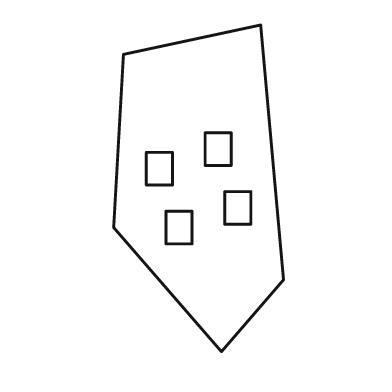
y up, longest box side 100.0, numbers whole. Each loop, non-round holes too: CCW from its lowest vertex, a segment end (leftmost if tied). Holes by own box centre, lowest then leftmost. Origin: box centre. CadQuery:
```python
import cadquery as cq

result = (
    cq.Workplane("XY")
    .moveTo(7.0, -50.0)
    .lineTo(26.0, -28.0)
    .lineTo(19.0, 50.0)
    .lineTo(-23.0, 41.0)
    .lineTo(-26.0, -12.0)
    .close()
    .moveTo(-10.0, -17.0)
    .lineTo(-2.0, -17.0)
    .lineTo(-2.0, -7.0)
    .lineTo(-10.0, -7.0)
    .close()
    .moveTo(8.0, -11.0)
    .lineTo(16.0, -11.0)
    .lineTo(16.0, -1.0)
    .lineTo(8.0, -1.0)
    .close()
    .moveTo(-16.0, 1.0)
    .lineTo(-8.0, 1.0)
    .lineTo(-8.0, 11.0)
    .lineTo(-16.0, 11.0)
    .close()
    .moveTo(2.0, 7.0)
    .lineTo(10.0, 7.0)
    .lineTo(10.0, 17.0)
    .lineTo(2.0, 17.0)
    .close()
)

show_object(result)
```